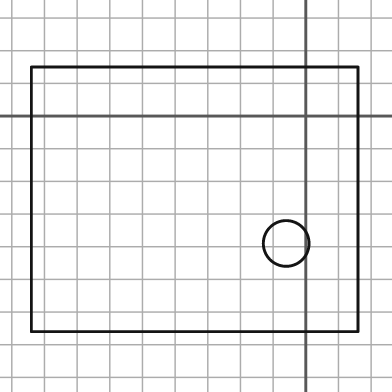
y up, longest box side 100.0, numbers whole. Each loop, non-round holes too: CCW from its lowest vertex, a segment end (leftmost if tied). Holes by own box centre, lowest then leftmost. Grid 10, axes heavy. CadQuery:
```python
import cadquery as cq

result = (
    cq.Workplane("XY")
    .moveTo(-84.0, -66.0)
    .lineTo(16.0, -66.0)
    .lineTo(16.0, 15.0)
    .lineTo(-84.0, 15.0)
    .close()
    .moveTo(-6.0, -39.0)
    .circle(7.0)
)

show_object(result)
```